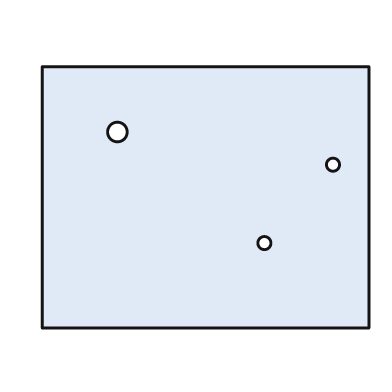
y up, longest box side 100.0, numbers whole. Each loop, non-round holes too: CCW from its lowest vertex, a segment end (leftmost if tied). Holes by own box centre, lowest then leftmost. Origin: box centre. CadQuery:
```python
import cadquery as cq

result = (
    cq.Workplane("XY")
    .moveTo(-50.0, -40.0)
    .lineTo(50.0, -40.0)
    .lineTo(50.0, 40.0)
    .lineTo(-50.0, 40.0)
    .close()
    .moveTo(18.0, -14.0)
    .circle(2.0)
    .moveTo(39.0, 10.0)
    .circle(2.0)
    .moveTo(-27.0, 20.0)
    .circle(3.0)
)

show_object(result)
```